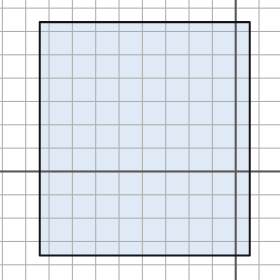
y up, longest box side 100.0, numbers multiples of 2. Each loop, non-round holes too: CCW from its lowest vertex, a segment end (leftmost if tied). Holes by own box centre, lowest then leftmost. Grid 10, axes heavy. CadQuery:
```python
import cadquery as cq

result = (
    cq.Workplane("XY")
    .moveTo(-84.0, -36.0)
    .lineTo(6.0, -36.0)
    .lineTo(6.0, 64.0)
    .lineTo(-84.0, 64.0)
    .close()
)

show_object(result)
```